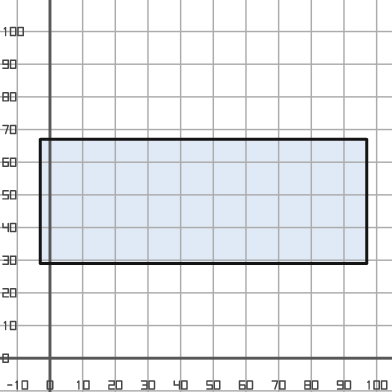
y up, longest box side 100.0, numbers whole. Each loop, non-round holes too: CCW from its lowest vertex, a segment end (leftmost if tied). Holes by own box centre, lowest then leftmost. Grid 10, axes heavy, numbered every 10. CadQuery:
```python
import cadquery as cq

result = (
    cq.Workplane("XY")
    .moveTo(-3.0, 29.0)
    .lineTo(97.0, 29.0)
    .lineTo(97.0, 67.0)
    .lineTo(-3.0, 67.0)
    .close()
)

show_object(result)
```